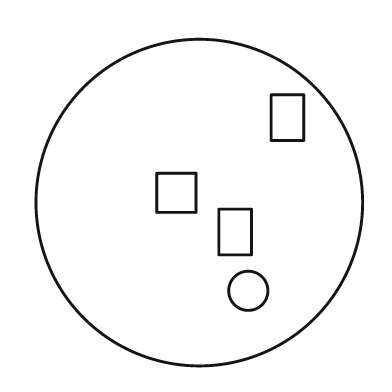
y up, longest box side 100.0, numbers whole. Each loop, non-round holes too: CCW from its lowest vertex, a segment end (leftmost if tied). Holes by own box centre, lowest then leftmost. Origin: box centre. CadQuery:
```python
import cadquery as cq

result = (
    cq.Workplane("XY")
    .moveTo(0.0, 0.0)
    .circle(50.0)
    .moveTo(15.0, -27.0)
    .circle(6.0)
    .moveTo(6.0, -16.0)
    .lineTo(16.0, -16.0)
    .lineTo(16.0, -2.0)
    .lineTo(6.0, -2.0)
    .close()
    .moveTo(-13.0, -3.0)
    .lineTo(-1.0, -3.0)
    .lineTo(-1.0, 9.0)
    .lineTo(-13.0, 9.0)
    .close()
    .moveTo(22.0, 19.0)
    .lineTo(32.0, 19.0)
    .lineTo(32.0, 33.0)
    .lineTo(22.0, 33.0)
    .close()
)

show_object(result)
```